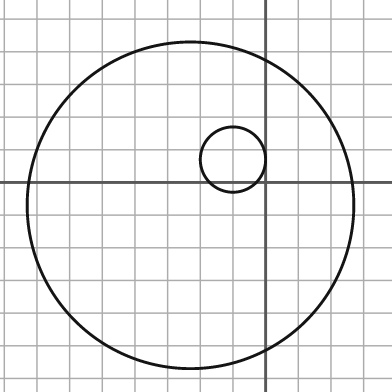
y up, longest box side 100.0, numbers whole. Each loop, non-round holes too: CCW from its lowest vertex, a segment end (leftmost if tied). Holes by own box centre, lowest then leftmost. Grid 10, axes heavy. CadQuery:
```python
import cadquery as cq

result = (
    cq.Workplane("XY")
    .moveTo(-23.0, -7.0)
    .circle(50.0)
    .moveTo(-10.0, 7.0)
    .circle(10.0)
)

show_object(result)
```